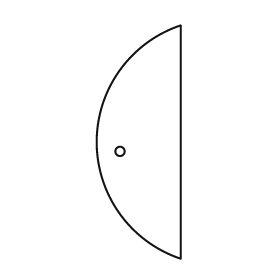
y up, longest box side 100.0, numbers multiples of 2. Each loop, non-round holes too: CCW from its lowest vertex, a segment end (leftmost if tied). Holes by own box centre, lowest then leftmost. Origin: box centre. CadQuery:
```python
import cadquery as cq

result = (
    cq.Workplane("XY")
    .moveTo(18.0, -50.0)
    .lineTo(18.0, 50.0)
    .threePointArc((-18.0, 0.0), (18.0, -50.0))
    .close()
    .moveTo(-8.0, -4.0)
    .circle(2.0)
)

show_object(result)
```